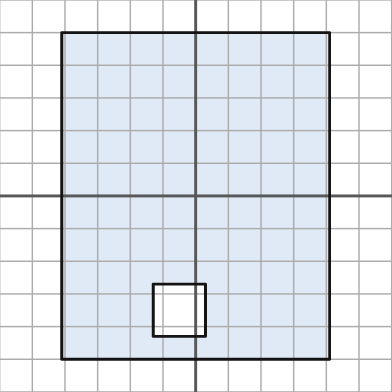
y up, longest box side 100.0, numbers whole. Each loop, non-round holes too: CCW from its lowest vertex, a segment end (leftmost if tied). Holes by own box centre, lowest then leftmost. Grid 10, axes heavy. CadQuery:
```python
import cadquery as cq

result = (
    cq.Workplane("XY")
    .moveTo(-41.0, -50.0)
    .lineTo(41.0, -50.0)
    .lineTo(41.0, 50.0)
    .lineTo(-41.0, 50.0)
    .close()
    .moveTo(-13.0, -43.0)
    .lineTo(3.0, -43.0)
    .lineTo(3.0, -27.0)
    .lineTo(-13.0, -27.0)
    .close()
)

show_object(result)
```